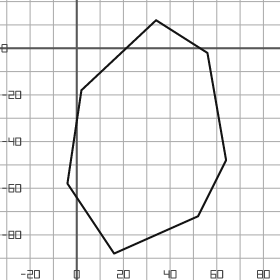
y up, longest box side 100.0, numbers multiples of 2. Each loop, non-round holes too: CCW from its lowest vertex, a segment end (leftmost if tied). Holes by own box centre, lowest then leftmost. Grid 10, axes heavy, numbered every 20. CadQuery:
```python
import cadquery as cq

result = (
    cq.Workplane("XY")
    .moveTo(16.0, -88.0)
    .lineTo(52.0, -72.0)
    .lineTo(64.0, -48.0)
    .lineTo(56.0, -2.0)
    .lineTo(34.0, 12.0)
    .lineTo(2.0, -18.0)
    .lineTo(-4.0, -58.0)
    .close()
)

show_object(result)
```